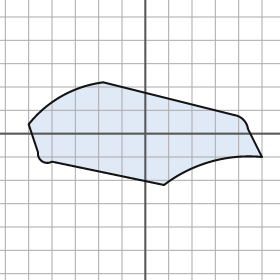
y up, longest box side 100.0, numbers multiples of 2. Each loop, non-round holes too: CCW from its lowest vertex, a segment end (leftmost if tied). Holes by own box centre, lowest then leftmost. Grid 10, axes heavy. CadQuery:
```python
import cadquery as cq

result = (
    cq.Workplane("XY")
    .moveTo(8.0, -22.0)
    .threePointArc((28.0, -12.0), (50.0, -10.0))
    .lineTo(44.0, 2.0)
    .threePointArc((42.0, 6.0), (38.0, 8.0))
    .lineTo(-18.0, 22.0)
    .threePointArc((-36.0, 16.0), (-50.0, 4.0))
    .lineTo(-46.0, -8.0)
    .threePointArc((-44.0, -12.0), (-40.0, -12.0))
    .close()
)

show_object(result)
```